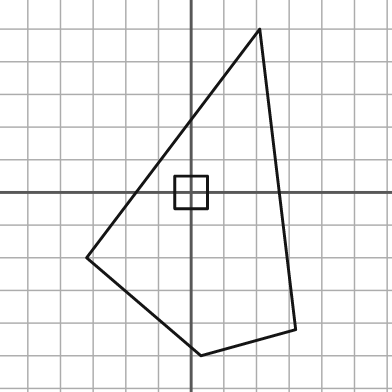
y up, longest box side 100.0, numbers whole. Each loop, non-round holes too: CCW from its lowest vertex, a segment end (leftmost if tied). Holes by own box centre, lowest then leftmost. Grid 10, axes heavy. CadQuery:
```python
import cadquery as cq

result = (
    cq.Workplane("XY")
    .moveTo(3.0, -50.0)
    .lineTo(32.0, -42.0)
    .lineTo(21.0, 50.0)
    .lineTo(-32.0, -20.0)
    .close()
    .moveTo(-5.0, -5.0)
    .lineTo(5.0, -5.0)
    .lineTo(5.0, 5.0)
    .lineTo(-5.0, 5.0)
    .close()
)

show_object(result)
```